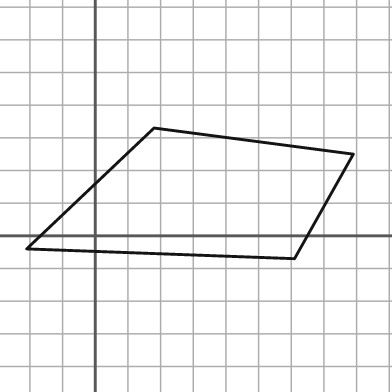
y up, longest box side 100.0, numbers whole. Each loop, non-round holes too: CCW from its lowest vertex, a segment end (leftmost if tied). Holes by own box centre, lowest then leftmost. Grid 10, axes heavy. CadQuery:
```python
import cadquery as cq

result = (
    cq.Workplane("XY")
    .moveTo(61.0, -7.0)
    .lineTo(79.0, 25.0)
    .lineTo(18.0, 33.0)
    .lineTo(-21.0, -4.0)
    .close()
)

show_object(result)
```